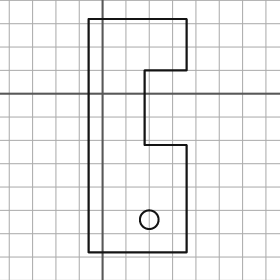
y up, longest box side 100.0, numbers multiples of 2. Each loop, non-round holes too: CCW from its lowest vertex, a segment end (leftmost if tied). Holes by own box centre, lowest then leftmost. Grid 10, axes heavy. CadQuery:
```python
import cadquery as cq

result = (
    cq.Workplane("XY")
    .moveTo(-6.0, -68.0)
    .lineTo(36.0, -68.0)
    .lineTo(36.0, -22.0)
    .lineTo(18.0, -22.0)
    .lineTo(18.0, 10.0)
    .lineTo(36.0, 10.0)
    .lineTo(36.0, 32.0)
    .lineTo(-6.0, 32.0)
    .close()
    .moveTo(20.0, -54.0)
    .circle(4.0)
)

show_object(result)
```